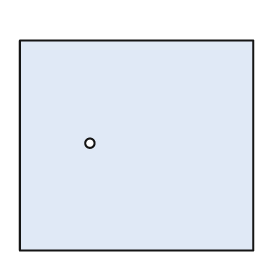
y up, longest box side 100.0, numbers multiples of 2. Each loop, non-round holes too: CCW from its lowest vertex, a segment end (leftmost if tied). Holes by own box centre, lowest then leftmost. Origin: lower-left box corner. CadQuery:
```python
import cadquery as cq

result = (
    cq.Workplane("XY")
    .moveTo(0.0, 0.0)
    .lineTo(100.0, 0.0)
    .lineTo(100.0, 90.0)
    .lineTo(0.0, 90.0)
    .close()
    .moveTo(30.0, 46.0)
    .circle(2.0)
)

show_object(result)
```